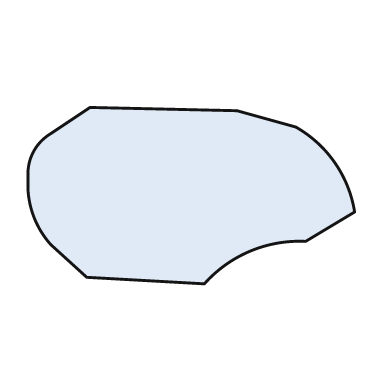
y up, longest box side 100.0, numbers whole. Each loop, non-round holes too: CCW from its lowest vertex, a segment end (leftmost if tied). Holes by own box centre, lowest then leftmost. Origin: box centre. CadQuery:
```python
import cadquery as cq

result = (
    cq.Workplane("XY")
    .moveTo(4.0, -27.0)
    .threePointArc((18.0, -17.0), (35.0, -14.0))
    .lineTo(50.0, -5.0)
    .threePointArc((44.0, 10.0), (32.0, 21.0))
    .lineTo(14.0, 26.0)
    .lineTo(-31.0, 27.0)
    .lineTo(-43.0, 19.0)
    .threePointArc((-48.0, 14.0), (-50.0, 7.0))
    .lineTo(-50.0, 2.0)
    .threePointArc((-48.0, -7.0), (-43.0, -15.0))
    .lineTo(-32.0, -25.0)
    .close()
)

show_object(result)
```